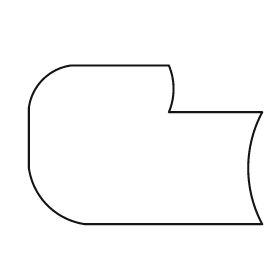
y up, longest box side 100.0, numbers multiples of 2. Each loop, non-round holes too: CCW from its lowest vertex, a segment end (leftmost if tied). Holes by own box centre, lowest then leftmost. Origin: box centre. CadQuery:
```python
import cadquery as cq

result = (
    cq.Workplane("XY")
    .moveTo(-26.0, -34.0)
    .lineTo(50.0, -34.0)
    .threePointArc((44.0, -10.0), (50.0, 14.0))
    .lineTo(10.0, 14.0)
    .threePointArc((12.0, 24.0), (10.0, 34.0))
    .lineTo(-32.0, 34.0)
    .threePointArc((-44.0, 28.0), (-50.0, 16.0))
    .lineTo(-50.0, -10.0)
    .threePointArc((-42.0, -26.0), (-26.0, -34.0))
    .close()
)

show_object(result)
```